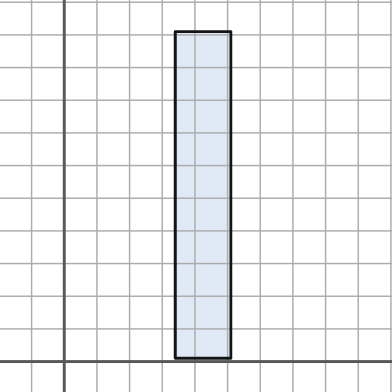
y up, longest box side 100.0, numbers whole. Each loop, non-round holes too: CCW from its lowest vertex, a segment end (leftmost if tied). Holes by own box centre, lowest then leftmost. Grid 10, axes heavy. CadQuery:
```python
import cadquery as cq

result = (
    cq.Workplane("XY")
    .moveTo(34.0, 1.0)
    .lineTo(51.0, 1.0)
    .lineTo(51.0, 101.0)
    .lineTo(34.0, 101.0)
    .close()
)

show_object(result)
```